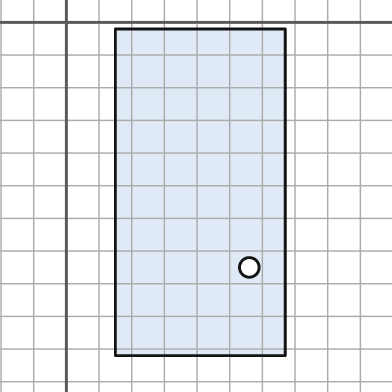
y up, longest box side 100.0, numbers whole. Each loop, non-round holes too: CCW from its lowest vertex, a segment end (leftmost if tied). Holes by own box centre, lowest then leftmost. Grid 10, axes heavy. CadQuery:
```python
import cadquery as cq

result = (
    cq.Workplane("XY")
    .moveTo(15.0, -102.0)
    .lineTo(67.0, -102.0)
    .lineTo(67.0, -2.0)
    .lineTo(15.0, -2.0)
    .close()
    .moveTo(56.0, -75.0)
    .circle(3.0)
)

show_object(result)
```